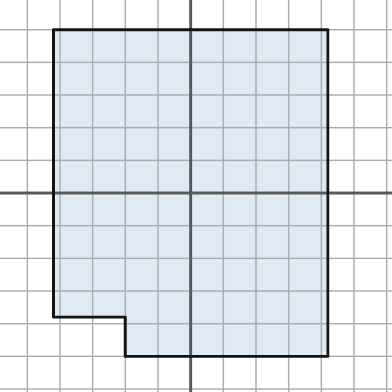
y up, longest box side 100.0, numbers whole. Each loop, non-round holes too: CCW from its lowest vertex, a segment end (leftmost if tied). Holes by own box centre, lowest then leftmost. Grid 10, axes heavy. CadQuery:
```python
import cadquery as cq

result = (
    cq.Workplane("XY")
    .moveTo(-20.0, -50.0)
    .lineTo(42.0, -50.0)
    .lineTo(42.0, 50.0)
    .lineTo(-42.0, 50.0)
    .lineTo(-42.0, -38.0)
    .lineTo(-20.0, -38.0)
    .close()
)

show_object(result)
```